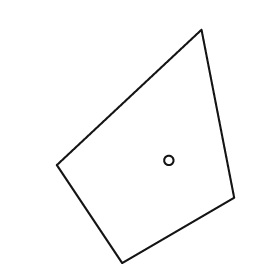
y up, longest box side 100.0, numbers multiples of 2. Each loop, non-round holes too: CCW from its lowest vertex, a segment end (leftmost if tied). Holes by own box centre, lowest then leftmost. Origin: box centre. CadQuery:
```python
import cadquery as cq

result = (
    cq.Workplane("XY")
    .moveTo(-10.0, -50.0)
    .lineTo(38.0, -22.0)
    .lineTo(24.0, 50.0)
    .lineTo(-38.0, -8.0)
    .close()
    .moveTo(10.0, -6.0)
    .circle(2.0)
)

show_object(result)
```